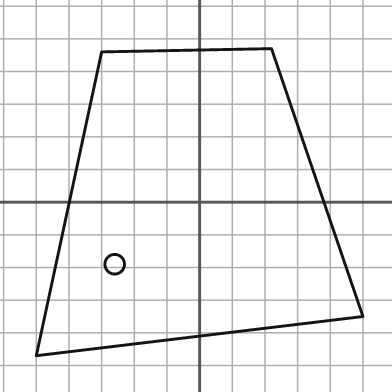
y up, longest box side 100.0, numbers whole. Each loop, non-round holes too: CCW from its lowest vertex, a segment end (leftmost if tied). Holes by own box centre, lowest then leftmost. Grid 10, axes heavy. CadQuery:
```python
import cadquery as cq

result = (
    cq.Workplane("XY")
    .moveTo(-50.0, -47.0)
    .lineTo(50.0, -35.0)
    .lineTo(22.0, 47.0)
    .lineTo(-30.0, 46.0)
    .close()
    .moveTo(-26.0, -19.0)
    .circle(3.0)
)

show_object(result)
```